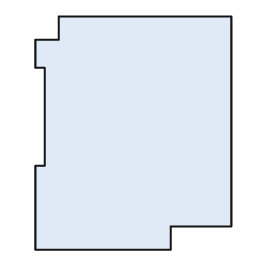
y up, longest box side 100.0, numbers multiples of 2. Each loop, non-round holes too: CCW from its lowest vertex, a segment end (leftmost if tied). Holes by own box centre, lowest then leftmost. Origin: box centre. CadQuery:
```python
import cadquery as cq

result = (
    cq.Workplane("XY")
    .moveTo(-42.0, -50.0)
    .lineTo(16.0, -50.0)
    .lineTo(16.0, -40.0)
    .lineTo(42.0, -40.0)
    .lineTo(42.0, 50.0)
    .lineTo(-32.0, 50.0)
    .lineTo(-32.0, 40.0)
    .lineTo(-42.0, 40.0)
    .lineTo(-42.0, 28.0)
    .lineTo(-38.0, 28.0)
    .lineTo(-38.0, -14.0)
    .lineTo(-42.0, -14.0)
    .close()
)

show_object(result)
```